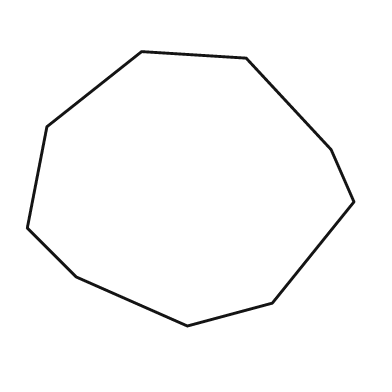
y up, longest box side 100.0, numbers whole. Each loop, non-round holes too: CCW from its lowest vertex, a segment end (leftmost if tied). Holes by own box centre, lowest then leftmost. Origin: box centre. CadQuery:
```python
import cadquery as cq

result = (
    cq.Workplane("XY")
    .moveTo(-1.0, -42.0)
    .lineTo(25.0, -35.0)
    .lineTo(50.0, -4.0)
    .lineTo(43.0, 12.0)
    .lineTo(17.0, 40.0)
    .lineTo(-15.0, 42.0)
    .lineTo(-44.0, 19.0)
    .lineTo(-50.0, -12.0)
    .lineTo(-35.0, -27.0)
    .close()
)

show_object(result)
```